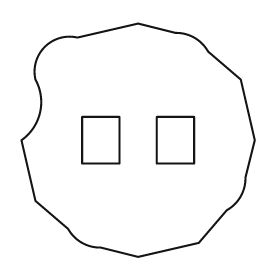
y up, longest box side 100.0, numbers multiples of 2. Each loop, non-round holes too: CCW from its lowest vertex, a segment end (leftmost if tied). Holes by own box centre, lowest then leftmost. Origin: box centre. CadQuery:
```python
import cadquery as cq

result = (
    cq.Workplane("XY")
    .moveTo(0.0, -50.0)
    .lineTo(26.0, -44.0)
    .lineTo(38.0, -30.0)
    .threePointArc((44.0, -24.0), (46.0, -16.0))
    .lineTo(50.0, 0.0)
    .lineTo(44.0, 26.0)
    .lineTo(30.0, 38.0)
    .threePointArc((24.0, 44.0), (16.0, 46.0))
    .lineTo(0.0, 50.0)
    .lineTo(-26.0, 44.0)
    .threePointArc((-40.0, 40.0), (-44.0, 26.0))
    .threePointArc((-42.0, 12.0), (-50.0, 0.0))
    .lineTo(-44.0, -26.0)
    .lineTo(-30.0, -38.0)
    .threePointArc((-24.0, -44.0), (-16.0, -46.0))
    .close()
    .moveTo(-24.0, -10.0)
    .lineTo(-8.0, -10.0)
    .lineTo(-8.0, 10.0)
    .lineTo(-24.0, 10.0)
    .close()
    .moveTo(8.0, -10.0)
    .lineTo(24.0, -10.0)
    .lineTo(24.0, 10.0)
    .lineTo(8.0, 10.0)
    .close()
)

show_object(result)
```